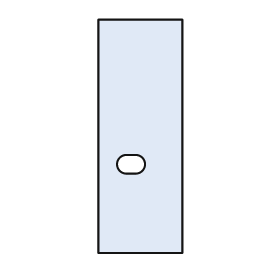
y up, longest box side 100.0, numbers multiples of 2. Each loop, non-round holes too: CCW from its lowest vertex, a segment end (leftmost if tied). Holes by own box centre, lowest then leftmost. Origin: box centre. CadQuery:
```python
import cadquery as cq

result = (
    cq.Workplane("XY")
    .moveTo(-18.0, -50.0)
    .lineTo(18.0, -50.0)
    .lineTo(18.0, 50.0)
    .lineTo(-18.0, 50.0)
    .close()
    .moveTo(-6.0, -16.0)
    .lineTo(-2.0, -16.0)
    .threePointArc((2.0, -12.0), (-2.0, -8.0))
    .lineTo(-6.0, -8.0)
    .threePointArc((-10.0, -12.0), (-6.0, -16.0))
    .close()
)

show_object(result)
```